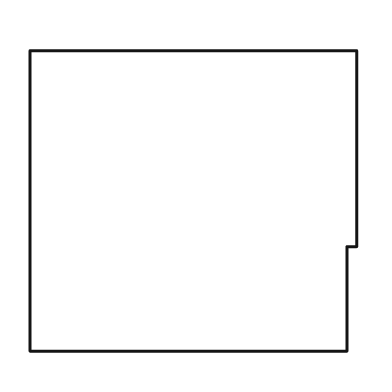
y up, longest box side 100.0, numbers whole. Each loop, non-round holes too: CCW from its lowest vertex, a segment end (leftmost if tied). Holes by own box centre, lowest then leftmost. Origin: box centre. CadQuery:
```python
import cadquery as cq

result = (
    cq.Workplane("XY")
    .moveTo(-50.0, -46.0)
    .lineTo(47.0, -46.0)
    .lineTo(47.0, -14.0)
    .lineTo(50.0, -14.0)
    .lineTo(50.0, 46.0)
    .lineTo(-50.0, 46.0)
    .close()
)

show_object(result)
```